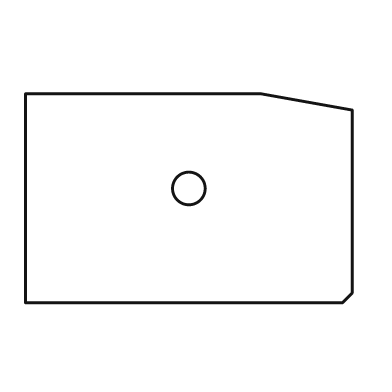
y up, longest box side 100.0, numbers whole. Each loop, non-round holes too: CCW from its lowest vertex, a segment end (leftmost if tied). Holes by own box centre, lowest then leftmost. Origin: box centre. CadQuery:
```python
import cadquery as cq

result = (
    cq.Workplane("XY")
    .moveTo(-50.0, -32.0)
    .lineTo(47.0, -32.0)
    .lineTo(50.0, -29.0)
    .lineTo(50.0, 27.0)
    .lineTo(22.0, 32.0)
    .lineTo(-50.0, 32.0)
    .close()
    .moveTo(0.0, 3.0)
    .circle(5.0)
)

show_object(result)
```